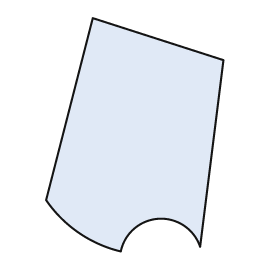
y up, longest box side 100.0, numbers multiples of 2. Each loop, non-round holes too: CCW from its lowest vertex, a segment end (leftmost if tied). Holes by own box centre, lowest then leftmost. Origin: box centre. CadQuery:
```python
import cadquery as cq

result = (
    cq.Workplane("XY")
    .moveTo(-6.0, -50.0)
    .threePointArc((10.0, -36.0), (28.0, -48.0))
    .lineTo(38.0, 32.0)
    .lineTo(-18.0, 50.0)
    .lineTo(-38.0, -28.0)
    .threePointArc((-24.0, -42.0), (-6.0, -50.0))
    .close()
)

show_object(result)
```